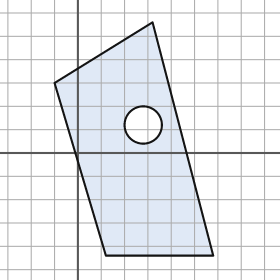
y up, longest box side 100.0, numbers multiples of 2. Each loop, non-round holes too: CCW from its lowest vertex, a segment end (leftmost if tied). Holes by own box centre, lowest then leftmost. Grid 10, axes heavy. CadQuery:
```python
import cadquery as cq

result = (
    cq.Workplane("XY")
    .moveTo(12.0, -44.0)
    .lineTo(58.0, -44.0)
    .lineTo(32.0, 56.0)
    .lineTo(-10.0, 30.0)
    .close()
    .moveTo(28.0, 12.0)
    .circle(8.0)
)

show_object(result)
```